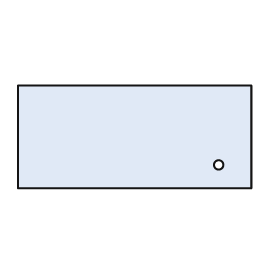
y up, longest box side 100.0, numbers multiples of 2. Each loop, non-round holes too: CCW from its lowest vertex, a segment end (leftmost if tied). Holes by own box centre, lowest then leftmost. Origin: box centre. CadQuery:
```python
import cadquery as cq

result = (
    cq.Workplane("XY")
    .moveTo(-50.0, -22.0)
    .lineTo(50.0, -22.0)
    .lineTo(50.0, 22.0)
    .lineTo(-50.0, 22.0)
    .close()
    .moveTo(36.0, -12.0)
    .circle(2.0)
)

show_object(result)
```